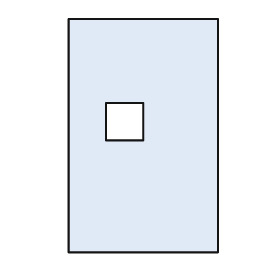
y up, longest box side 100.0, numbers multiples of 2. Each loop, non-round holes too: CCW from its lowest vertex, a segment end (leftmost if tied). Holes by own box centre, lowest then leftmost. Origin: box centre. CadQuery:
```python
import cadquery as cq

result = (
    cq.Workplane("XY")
    .moveTo(-32.0, -50.0)
    .lineTo(32.0, -50.0)
    .lineTo(32.0, 50.0)
    .lineTo(-32.0, 50.0)
    .close()
    .moveTo(-16.0, -2.0)
    .lineTo(0.0, -2.0)
    .lineTo(0.0, 14.0)
    .lineTo(-16.0, 14.0)
    .close()
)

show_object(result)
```